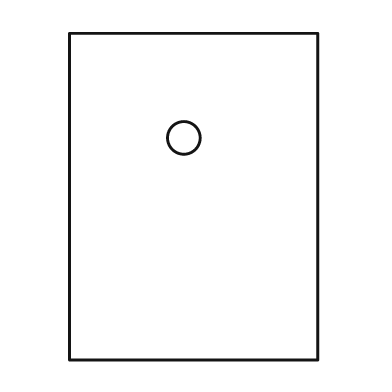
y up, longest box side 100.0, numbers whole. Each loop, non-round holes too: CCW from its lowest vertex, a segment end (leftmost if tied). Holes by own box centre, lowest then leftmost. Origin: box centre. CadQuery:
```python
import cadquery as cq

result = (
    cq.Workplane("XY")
    .moveTo(-38.0, -50.0)
    .lineTo(38.0, -50.0)
    .lineTo(38.0, 50.0)
    .lineTo(-38.0, 50.0)
    .close()
    .moveTo(-3.0, 18.0)
    .circle(5.0)
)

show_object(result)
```